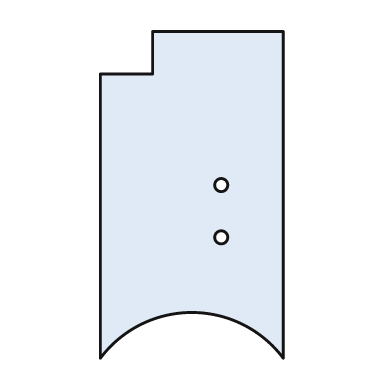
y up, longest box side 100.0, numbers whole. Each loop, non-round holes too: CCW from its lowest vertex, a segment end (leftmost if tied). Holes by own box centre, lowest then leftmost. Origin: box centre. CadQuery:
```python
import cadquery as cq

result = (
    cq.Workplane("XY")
    .moveTo(-28.0, -50.0)
    .threePointArc((0.0, -36.0), (28.0, -50.0))
    .lineTo(28.0, 50.0)
    .lineTo(-12.0, 50.0)
    .lineTo(-12.0, 37.0)
    .lineTo(-28.0, 37.0)
    .close()
    .moveTo(9.0, -13.0)
    .circle(2.0)
    .moveTo(9.0, 3.0)
    .circle(2.0)
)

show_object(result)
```